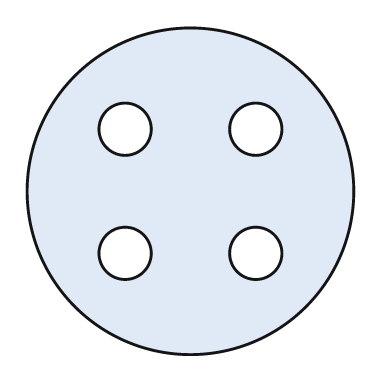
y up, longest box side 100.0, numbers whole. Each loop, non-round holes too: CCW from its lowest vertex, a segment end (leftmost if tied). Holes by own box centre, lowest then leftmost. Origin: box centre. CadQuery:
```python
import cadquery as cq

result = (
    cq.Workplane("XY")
    .moveTo(0.0, 0.0)
    .circle(50.0)
    .moveTo(-20.0, -19.0)
    .circle(8.0)
    .moveTo(20.0, -19.0)
    .circle(8.0)
    .moveTo(-20.0, 19.0)
    .circle(8.0)
    .moveTo(20.0, 19.0)
    .circle(8.0)
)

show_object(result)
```